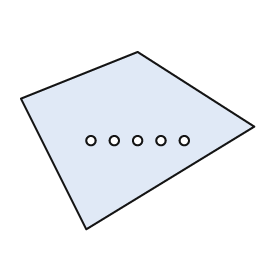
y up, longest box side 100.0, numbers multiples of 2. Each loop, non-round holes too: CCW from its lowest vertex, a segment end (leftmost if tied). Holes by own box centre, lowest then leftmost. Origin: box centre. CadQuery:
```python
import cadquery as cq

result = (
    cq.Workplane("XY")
    .moveTo(-22.0, -38.0)
    .lineTo(50.0, 6.0)
    .lineTo(0.0, 38.0)
    .lineTo(-50.0, 18.0)
    .close()
    .moveTo(-20.0, 0.0)
    .circle(2.0)
    .moveTo(-10.0, 0.0)
    .circle(2.0)
    .moveTo(0.0, 0.0)
    .circle(2.0)
    .moveTo(10.0, 0.0)
    .circle(2.0)
    .moveTo(20.0, 0.0)
    .circle(2.0)
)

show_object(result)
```